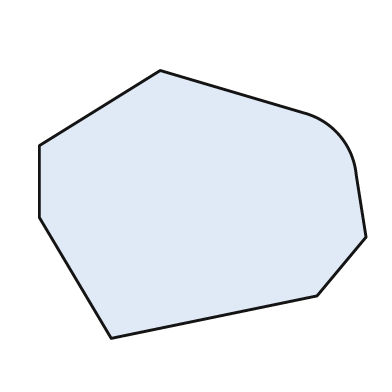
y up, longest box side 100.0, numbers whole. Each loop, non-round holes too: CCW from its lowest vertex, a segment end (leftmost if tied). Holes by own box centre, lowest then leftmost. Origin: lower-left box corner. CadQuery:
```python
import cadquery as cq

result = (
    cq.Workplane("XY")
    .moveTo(22.0, 0.0)
    .lineTo(85.0, 13.0)
    .lineTo(100.0, 31.0)
    .lineTo(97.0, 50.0)
    .threePointArc((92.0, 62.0), (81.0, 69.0))
    .lineTo(37.0, 82.0)
    .lineTo(0.0, 59.0)
    .lineTo(0.0, 37.0)
    .close()
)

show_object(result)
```